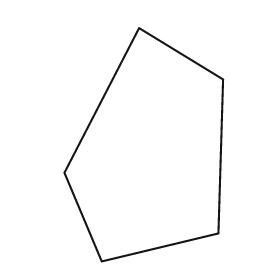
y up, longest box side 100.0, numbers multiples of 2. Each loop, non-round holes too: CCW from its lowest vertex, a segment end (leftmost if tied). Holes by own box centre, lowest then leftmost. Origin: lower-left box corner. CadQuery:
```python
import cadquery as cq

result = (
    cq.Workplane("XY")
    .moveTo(16.0, 0.0)
    .lineTo(66.0, 12.0)
    .lineTo(68.0, 78.0)
    .lineTo(32.0, 100.0)
    .lineTo(0.0, 38.0)
    .close()
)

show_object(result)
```